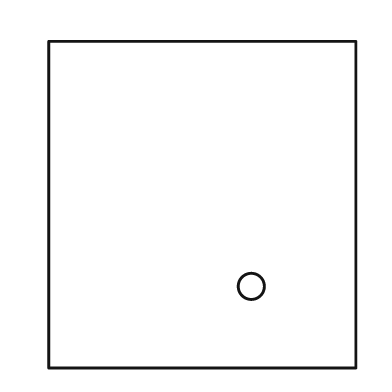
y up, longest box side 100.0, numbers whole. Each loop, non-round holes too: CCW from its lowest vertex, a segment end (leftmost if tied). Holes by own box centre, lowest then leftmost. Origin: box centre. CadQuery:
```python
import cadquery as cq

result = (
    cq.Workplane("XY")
    .moveTo(-47.0, -50.0)
    .lineTo(47.0, -50.0)
    .lineTo(47.0, 50.0)
    .lineTo(-47.0, 50.0)
    .close()
    .moveTo(15.0, -25.0)
    .circle(4.0)
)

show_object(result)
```